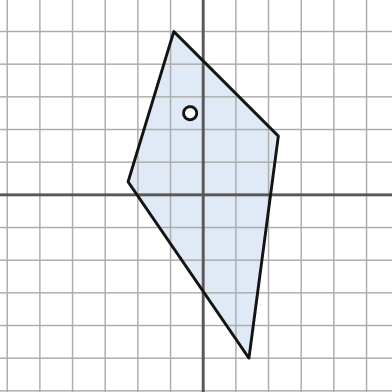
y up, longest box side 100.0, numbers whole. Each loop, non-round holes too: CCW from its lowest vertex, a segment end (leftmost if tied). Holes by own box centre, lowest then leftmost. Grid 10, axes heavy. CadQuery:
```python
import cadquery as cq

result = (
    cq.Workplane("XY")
    .moveTo(14.0, -50.0)
    .lineTo(23.0, 18.0)
    .lineTo(-9.0, 50.0)
    .lineTo(-23.0, 4.0)
    .close()
    .moveTo(-4.0, 25.0)
    .circle(2.0)
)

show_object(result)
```